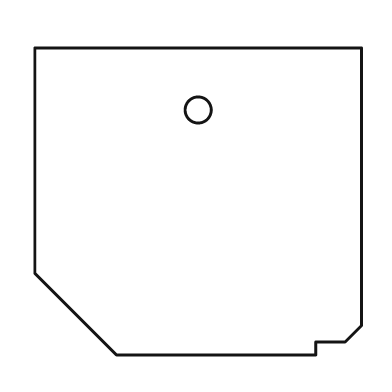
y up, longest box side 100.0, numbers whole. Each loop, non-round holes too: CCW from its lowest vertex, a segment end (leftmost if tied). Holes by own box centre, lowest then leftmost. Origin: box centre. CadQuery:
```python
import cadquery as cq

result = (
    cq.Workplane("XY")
    .moveTo(-25.0, -47.0)
    .lineTo(36.0, -47.0)
    .lineTo(36.0, -43.0)
    .lineTo(45.0, -43.0)
    .lineTo(50.0, -38.0)
    .lineTo(50.0, 47.0)
    .lineTo(-50.0, 47.0)
    .lineTo(-50.0, -22.0)
    .close()
    .moveTo(0.0, 28.0)
    .circle(4.0)
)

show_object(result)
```